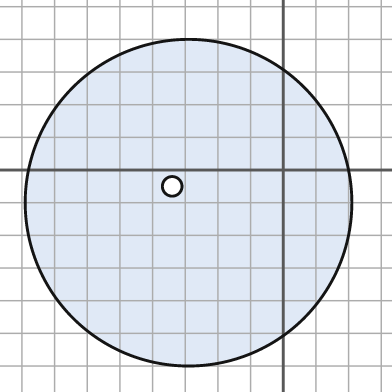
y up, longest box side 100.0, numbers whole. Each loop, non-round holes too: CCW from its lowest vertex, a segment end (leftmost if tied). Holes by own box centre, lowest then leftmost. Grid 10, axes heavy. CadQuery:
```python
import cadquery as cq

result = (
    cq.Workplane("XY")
    .moveTo(-29.0, -10.0)
    .circle(50.0)
    .moveTo(-34.0, -5.0)
    .circle(3.0)
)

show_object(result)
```